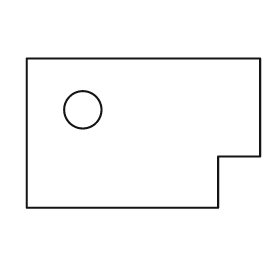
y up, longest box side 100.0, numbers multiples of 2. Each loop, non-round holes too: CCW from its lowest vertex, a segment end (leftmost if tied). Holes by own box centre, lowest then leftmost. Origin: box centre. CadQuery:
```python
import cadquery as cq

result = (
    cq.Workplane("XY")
    .moveTo(-50.0, -32.0)
    .lineTo(32.0, -32.0)
    .lineTo(32.0, -10.0)
    .lineTo(50.0, -10.0)
    .lineTo(50.0, 32.0)
    .lineTo(-50.0, 32.0)
    .close()
    .moveTo(-26.0, 10.0)
    .circle(8.0)
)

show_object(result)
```